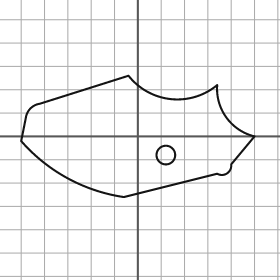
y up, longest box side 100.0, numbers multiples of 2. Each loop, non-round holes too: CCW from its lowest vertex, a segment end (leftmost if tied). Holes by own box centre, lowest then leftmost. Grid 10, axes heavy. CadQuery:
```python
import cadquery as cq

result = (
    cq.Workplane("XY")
    .moveTo(-6.0, -26.0)
    .lineTo(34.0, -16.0)
    .threePointArc((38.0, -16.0), (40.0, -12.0))
    .lineTo(50.0, 0.0)
    .threePointArc((38.0, 8.0), (34.0, 22.0))
    .threePointArc((14.0, 16.0), (-4.0, 26.0))
    .lineTo(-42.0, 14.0)
    .threePointArc((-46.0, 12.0), (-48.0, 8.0))
    .lineTo(-50.0, -2.0)
    .threePointArc((-30.0, -18.0), (-6.0, -26.0))
    .close()
    .moveTo(12.0, -8.0)
    .circle(4.0)
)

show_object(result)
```